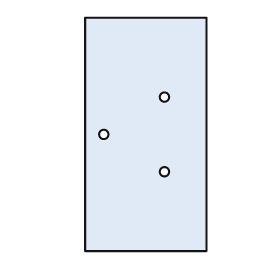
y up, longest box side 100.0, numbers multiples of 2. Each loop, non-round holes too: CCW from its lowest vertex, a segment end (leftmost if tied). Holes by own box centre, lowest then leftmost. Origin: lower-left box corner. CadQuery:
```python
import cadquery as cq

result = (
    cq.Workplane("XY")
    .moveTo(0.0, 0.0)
    .lineTo(52.0, 0.0)
    .lineTo(52.0, 100.0)
    .lineTo(0.0, 100.0)
    .close()
    .moveTo(34.0, 34.0)
    .circle(2.0)
    .moveTo(8.0, 50.0)
    .circle(2.0)
    .moveTo(34.0, 66.0)
    .circle(2.0)
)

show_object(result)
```